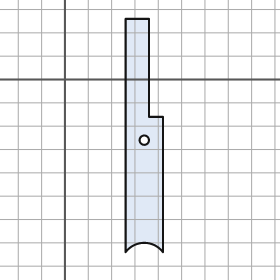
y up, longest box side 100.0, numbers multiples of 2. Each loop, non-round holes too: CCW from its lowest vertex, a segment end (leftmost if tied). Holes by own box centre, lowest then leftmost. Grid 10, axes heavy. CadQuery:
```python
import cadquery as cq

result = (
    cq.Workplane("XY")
    .moveTo(26.0, -74.0)
    .threePointArc((34.0, -70.0), (42.0, -74.0))
    .lineTo(42.0, -16.0)
    .lineTo(36.0, -16.0)
    .lineTo(36.0, 26.0)
    .lineTo(26.0, 26.0)
    .close()
    .moveTo(34.0, -26.0)
    .circle(2.0)
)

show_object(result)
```